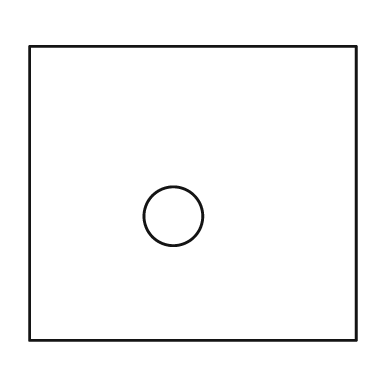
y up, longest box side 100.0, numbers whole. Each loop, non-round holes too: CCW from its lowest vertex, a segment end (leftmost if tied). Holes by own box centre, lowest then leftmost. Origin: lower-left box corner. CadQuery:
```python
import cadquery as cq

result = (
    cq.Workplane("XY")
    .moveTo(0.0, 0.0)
    .lineTo(100.0, 0.0)
    .lineTo(100.0, 90.0)
    .lineTo(0.0, 90.0)
    .close()
    .moveTo(44.0, 38.0)
    .circle(9.0)
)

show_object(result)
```